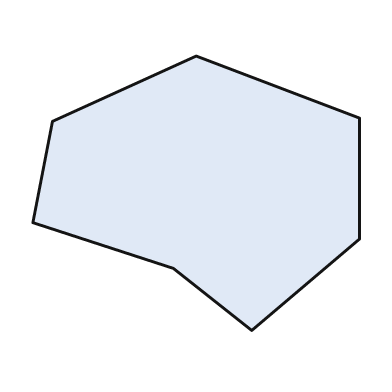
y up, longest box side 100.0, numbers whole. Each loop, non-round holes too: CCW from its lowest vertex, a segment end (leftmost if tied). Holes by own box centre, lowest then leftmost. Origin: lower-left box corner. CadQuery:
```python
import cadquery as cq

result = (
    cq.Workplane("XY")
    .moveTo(67.0, 0.0)
    .lineTo(100.0, 28.0)
    .lineTo(100.0, 65.0)
    .lineTo(50.0, 84.0)
    .lineTo(6.0, 64.0)
    .lineTo(0.0, 33.0)
    .lineTo(43.0, 19.0)
    .close()
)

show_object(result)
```